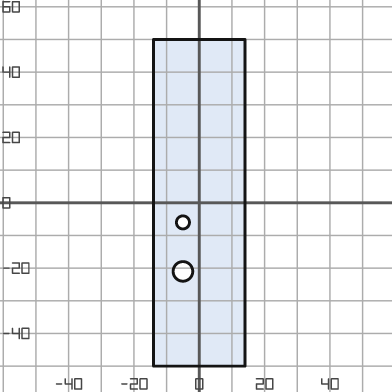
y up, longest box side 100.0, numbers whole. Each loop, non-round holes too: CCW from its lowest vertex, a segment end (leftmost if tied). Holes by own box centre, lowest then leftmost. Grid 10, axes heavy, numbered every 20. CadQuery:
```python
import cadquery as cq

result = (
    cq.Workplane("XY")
    .moveTo(-14.0, -50.0)
    .lineTo(14.0, -50.0)
    .lineTo(14.0, 50.0)
    .lineTo(-14.0, 50.0)
    .close()
    .moveTo(-5.0, -21.0)
    .circle(3.0)
    .moveTo(-5.0, -6.0)
    .circle(2.0)
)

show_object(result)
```